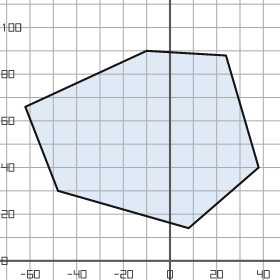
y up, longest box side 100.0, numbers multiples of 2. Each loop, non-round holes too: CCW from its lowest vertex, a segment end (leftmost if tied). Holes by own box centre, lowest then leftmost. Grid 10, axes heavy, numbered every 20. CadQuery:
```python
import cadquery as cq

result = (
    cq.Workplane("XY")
    .moveTo(8.0, 14.0)
    .lineTo(38.0, 40.0)
    .lineTo(24.0, 88.0)
    .lineTo(-10.0, 90.0)
    .lineTo(-62.0, 66.0)
    .lineTo(-48.0, 30.0)
    .close()
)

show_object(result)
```